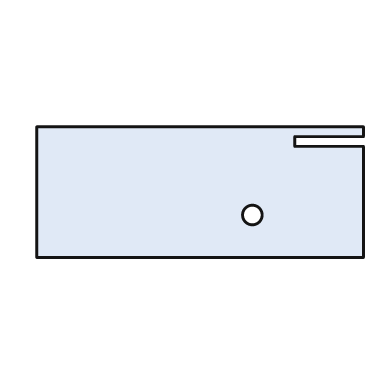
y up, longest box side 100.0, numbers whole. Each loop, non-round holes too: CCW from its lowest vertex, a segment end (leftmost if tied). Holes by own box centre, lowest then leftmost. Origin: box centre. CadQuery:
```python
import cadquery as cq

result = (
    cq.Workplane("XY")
    .moveTo(-50.0, -20.0)
    .lineTo(50.0, -20.0)
    .lineTo(50.0, 14.0)
    .lineTo(29.0, 14.0)
    .lineTo(29.0, 17.0)
    .lineTo(50.0, 17.0)
    .lineTo(50.0, 20.0)
    .lineTo(-50.0, 20.0)
    .close()
    .moveTo(16.0, -7.0)
    .circle(3.0)
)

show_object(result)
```